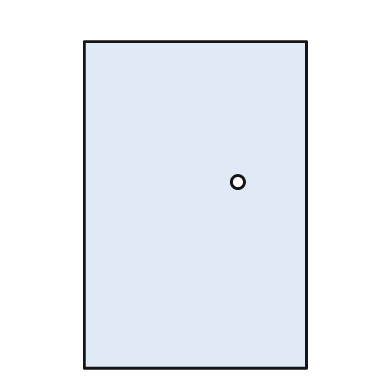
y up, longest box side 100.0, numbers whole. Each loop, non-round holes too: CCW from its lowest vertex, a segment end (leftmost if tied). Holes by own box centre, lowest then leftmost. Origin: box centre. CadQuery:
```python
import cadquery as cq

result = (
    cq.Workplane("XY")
    .moveTo(-34.0, -50.0)
    .lineTo(34.0, -50.0)
    .lineTo(34.0, 50.0)
    .lineTo(-34.0, 50.0)
    .close()
    .moveTo(13.0, 7.0)
    .circle(2.0)
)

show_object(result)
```